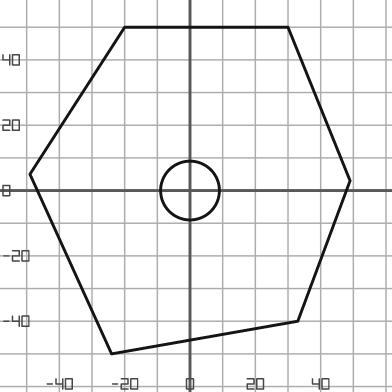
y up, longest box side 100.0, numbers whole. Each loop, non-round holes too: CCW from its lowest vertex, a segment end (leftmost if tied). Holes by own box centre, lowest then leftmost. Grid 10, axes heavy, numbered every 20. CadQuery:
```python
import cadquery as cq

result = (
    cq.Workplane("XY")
    .moveTo(-24.0, -50.0)
    .lineTo(33.0, -40.0)
    .lineTo(49.0, 3.0)
    .lineTo(30.0, 50.0)
    .lineTo(-20.0, 50.0)
    .lineTo(-49.0, 5.0)
    .close()
    .moveTo(0.0, 0.0)
    .circle(9.0)
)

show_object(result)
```